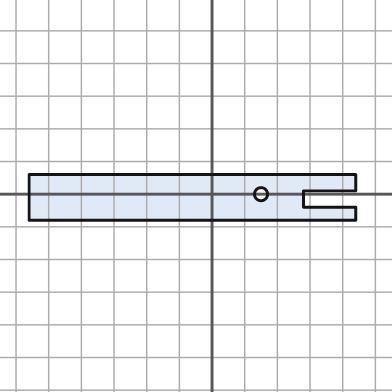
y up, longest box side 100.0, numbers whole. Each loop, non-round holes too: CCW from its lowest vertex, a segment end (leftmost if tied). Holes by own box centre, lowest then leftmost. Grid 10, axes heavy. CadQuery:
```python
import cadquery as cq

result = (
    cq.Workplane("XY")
    .moveTo(-56.0, -8.0)
    .lineTo(44.0, -8.0)
    .lineTo(44.0, -4.0)
    .lineTo(28.0, -4.0)
    .lineTo(28.0, 1.0)
    .lineTo(44.0, 1.0)
    .lineTo(44.0, 6.0)
    .lineTo(-56.0, 6.0)
    .close()
    .moveTo(15.0, 0.0)
    .circle(2.0)
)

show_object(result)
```